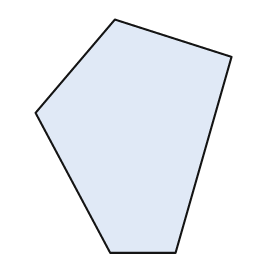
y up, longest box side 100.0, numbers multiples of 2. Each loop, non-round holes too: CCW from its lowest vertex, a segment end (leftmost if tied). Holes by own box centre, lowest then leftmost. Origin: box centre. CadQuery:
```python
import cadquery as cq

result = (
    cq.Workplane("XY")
    .moveTo(-10.0, -50.0)
    .lineTo(18.0, -50.0)
    .lineTo(42.0, 34.0)
    .lineTo(-8.0, 50.0)
    .lineTo(-42.0, 10.0)
    .close()
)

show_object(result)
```